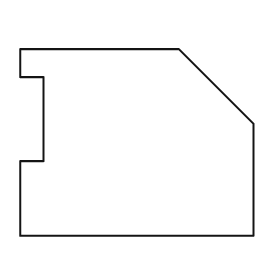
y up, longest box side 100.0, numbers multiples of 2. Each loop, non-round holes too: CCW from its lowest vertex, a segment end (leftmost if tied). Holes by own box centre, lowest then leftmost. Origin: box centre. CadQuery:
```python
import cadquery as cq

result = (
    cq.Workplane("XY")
    .moveTo(-50.0, -40.0)
    .lineTo(50.0, -40.0)
    .lineTo(50.0, 8.0)
    .lineTo(18.0, 40.0)
    .lineTo(-50.0, 40.0)
    .lineTo(-50.0, 28.0)
    .lineTo(-40.0, 28.0)
    .lineTo(-40.0, -8.0)
    .lineTo(-50.0, -8.0)
    .close()
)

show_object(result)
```